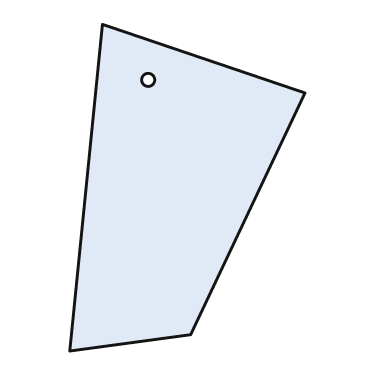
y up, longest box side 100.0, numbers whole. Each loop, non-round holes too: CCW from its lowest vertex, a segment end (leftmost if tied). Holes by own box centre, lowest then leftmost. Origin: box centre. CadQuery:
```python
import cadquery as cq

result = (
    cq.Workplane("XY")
    .moveTo(-36.0, -50.0)
    .lineTo(1.0, -45.0)
    .lineTo(36.0, 29.0)
    .lineTo(-26.0, 50.0)
    .close()
    .moveTo(-12.0, 33.0)
    .circle(2.0)
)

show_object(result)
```